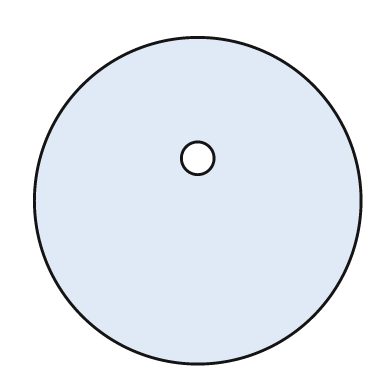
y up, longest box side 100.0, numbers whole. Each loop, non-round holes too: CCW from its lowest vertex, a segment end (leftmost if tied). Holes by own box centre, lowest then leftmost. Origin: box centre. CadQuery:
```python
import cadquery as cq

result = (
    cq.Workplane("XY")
    .moveTo(0.0, 0.0)
    .circle(50.0)
    .moveTo(0.0, 13.0)
    .circle(5.0)
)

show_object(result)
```